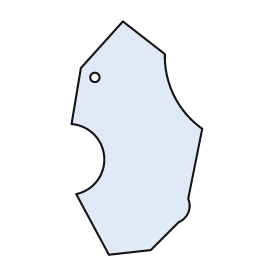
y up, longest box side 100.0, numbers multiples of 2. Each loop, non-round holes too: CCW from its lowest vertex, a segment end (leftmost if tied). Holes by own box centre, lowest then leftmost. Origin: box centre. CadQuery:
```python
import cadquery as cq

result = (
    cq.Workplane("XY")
    .moveTo(-12.0, -50.0)
    .lineTo(6.0, -48.0)
    .lineTo(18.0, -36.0)
    .threePointArc((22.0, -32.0), (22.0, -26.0))
    .lineTo(28.0, 4.0)
    .threePointArc((16.0, 18.0), (12.0, 36.0))
    .lineTo(-6.0, 50.0)
    .lineTo(-24.0, 30.0)
    .lineTo(-28.0, 6.0)
    .threePointArc((-14.0, -8.0), (-26.0, -24.0))
    .close()
    .moveTo(-18.0, 26.0)
    .circle(2.0)
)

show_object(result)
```